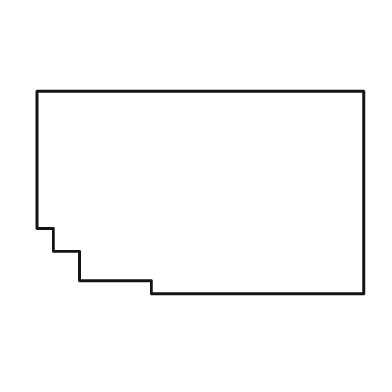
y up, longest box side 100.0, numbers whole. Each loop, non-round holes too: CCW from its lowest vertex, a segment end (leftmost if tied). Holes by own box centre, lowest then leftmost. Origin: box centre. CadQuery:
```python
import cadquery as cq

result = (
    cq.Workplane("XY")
    .moveTo(-15.0, -31.0)
    .lineTo(50.0, -31.0)
    .lineTo(50.0, 31.0)
    .lineTo(-50.0, 31.0)
    .lineTo(-50.0, -11.0)
    .lineTo(-45.0, -11.0)
    .lineTo(-45.0, -18.0)
    .lineTo(-37.0, -18.0)
    .lineTo(-37.0, -27.0)
    .lineTo(-15.0, -27.0)
    .close()
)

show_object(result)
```